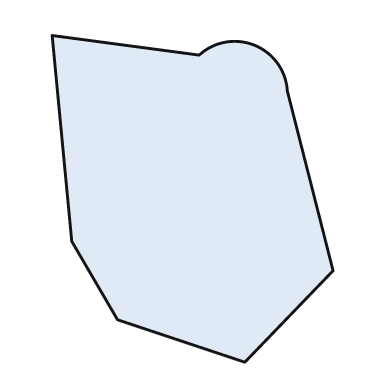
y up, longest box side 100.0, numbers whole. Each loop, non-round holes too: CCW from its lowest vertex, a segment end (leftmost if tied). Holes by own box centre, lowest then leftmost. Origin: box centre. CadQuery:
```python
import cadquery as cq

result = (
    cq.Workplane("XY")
    .moveTo(16.0, -50.0)
    .lineTo(43.0, -22.0)
    .lineTo(29.0, 33.0)
    .threePointArc((19.0, 47.0), (2.0, 44.0))
    .lineTo(-43.0, 50.0)
    .lineTo(-37.0, -13.0)
    .lineTo(-23.0, -37.0)
    .close()
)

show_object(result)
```